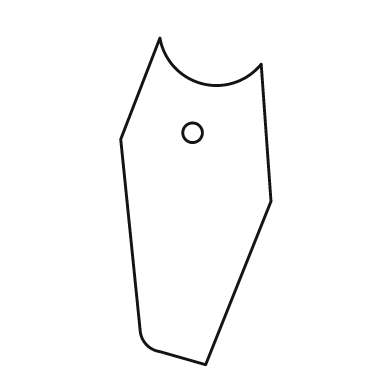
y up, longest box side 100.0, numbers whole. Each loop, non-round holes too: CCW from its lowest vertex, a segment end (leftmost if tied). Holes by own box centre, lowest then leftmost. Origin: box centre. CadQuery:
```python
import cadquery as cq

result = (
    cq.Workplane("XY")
    .moveTo(3.0, -50.0)
    .lineTo(23.0, 0.0)
    .lineTo(20.0, 42.0)
    .threePointArc((2.0, 36.0), (-11.0, 50.0))
    .lineTo(-23.0, 19.0)
    .lineTo(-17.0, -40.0)
    .threePointArc((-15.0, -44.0), (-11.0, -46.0))
    .close()
    .moveTo(-1.0, 21.0)
    .circle(3.0)
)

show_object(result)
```